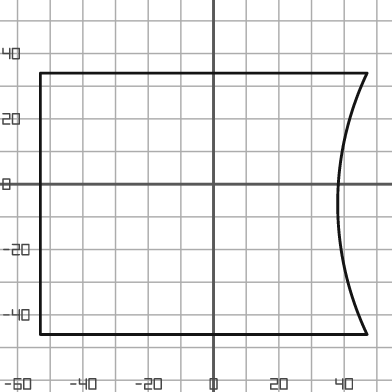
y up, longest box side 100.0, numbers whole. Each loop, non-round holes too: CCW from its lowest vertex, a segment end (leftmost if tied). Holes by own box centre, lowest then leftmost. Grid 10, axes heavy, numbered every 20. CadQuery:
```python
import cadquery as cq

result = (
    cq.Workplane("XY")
    .moveTo(-53.0, -46.0)
    .lineTo(47.0, -46.0)
    .threePointArc((38.0, -6.0), (47.0, 34.0))
    .lineTo(-53.0, 34.0)
    .close()
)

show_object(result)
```